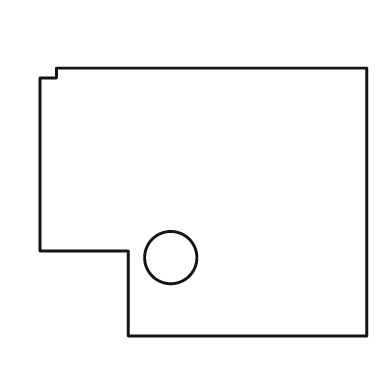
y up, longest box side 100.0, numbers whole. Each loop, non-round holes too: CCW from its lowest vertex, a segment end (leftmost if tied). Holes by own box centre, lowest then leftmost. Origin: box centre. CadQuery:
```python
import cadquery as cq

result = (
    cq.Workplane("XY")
    .moveTo(-23.0, -41.0)
    .lineTo(50.0, -41.0)
    .lineTo(50.0, 41.0)
    .lineTo(-45.0, 41.0)
    .lineTo(-45.0, 38.0)
    .lineTo(-50.0, 38.0)
    .lineTo(-50.0, -15.0)
    .lineTo(-23.0, -15.0)
    .close()
    .moveTo(-10.0, -17.0)
    .circle(8.0)
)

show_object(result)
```